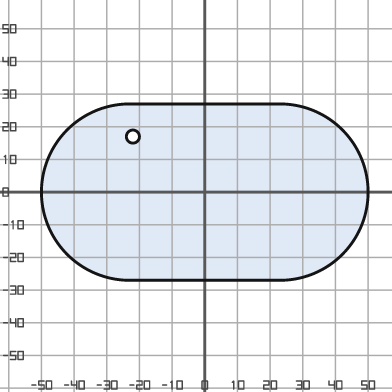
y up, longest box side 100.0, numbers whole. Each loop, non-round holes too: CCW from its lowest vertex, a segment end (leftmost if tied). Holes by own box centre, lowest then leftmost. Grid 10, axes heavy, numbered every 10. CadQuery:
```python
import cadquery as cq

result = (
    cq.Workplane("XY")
    .moveTo(-23.0, -27.0)
    .lineTo(23.0, -27.0)
    .threePointArc((50.0, 0.0), (23.0, 27.0))
    .lineTo(-23.0, 27.0)
    .threePointArc((-50.0, 0.0), (-23.0, -27.0))
    .close()
    .moveTo(-22.0, 17.0)
    .circle(2.0)
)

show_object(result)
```